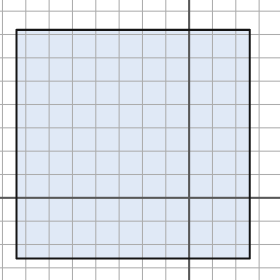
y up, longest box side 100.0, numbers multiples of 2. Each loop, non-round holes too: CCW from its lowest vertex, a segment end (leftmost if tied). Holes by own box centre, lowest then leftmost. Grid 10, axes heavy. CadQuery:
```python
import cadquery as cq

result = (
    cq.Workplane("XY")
    .moveTo(-74.0, -26.0)
    .lineTo(26.0, -26.0)
    .lineTo(26.0, 72.0)
    .lineTo(-74.0, 72.0)
    .close()
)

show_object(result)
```